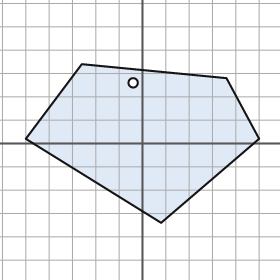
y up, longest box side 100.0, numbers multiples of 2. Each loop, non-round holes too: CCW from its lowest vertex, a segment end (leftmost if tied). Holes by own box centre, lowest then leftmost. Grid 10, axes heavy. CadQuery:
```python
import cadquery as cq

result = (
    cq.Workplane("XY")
    .moveTo(8.0, -34.0)
    .lineTo(50.0, 2.0)
    .lineTo(36.0, 28.0)
    .lineTo(-26.0, 34.0)
    .lineTo(-50.0, 2.0)
    .close()
    .moveTo(-4.0, 26.0)
    .circle(2.0)
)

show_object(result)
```